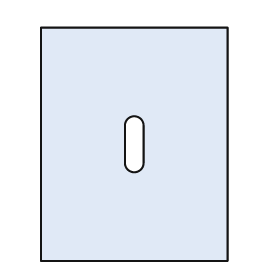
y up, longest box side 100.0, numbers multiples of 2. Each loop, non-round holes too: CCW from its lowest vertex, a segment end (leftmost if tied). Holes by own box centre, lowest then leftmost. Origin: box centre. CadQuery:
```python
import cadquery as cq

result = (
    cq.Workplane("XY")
    .moveTo(-40.0, -50.0)
    .lineTo(40.0, -50.0)
    .lineTo(40.0, 50.0)
    .lineTo(-40.0, 50.0)
    .close()
    .moveTo(-4.0, -8.0)
    .threePointArc((0.0, -12.0), (4.0, -8.0))
    .lineTo(4.0, 8.0)
    .threePointArc((0.0, 12.0), (-4.0, 8.0))
    .close()
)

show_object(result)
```